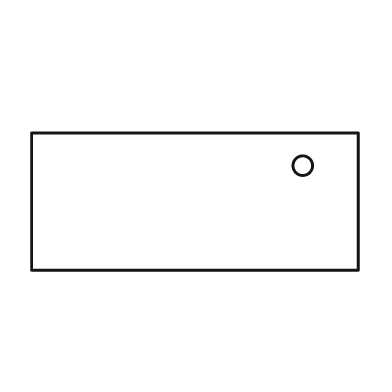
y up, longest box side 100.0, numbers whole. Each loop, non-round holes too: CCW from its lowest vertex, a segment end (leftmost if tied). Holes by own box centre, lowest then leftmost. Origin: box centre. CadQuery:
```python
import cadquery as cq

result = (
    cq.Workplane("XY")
    .moveTo(-50.0, -21.0)
    .lineTo(50.0, -21.0)
    .lineTo(50.0, 21.0)
    .lineTo(-50.0, 21.0)
    .close()
    .moveTo(33.0, 11.0)
    .circle(3.0)
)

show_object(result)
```